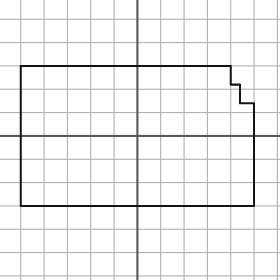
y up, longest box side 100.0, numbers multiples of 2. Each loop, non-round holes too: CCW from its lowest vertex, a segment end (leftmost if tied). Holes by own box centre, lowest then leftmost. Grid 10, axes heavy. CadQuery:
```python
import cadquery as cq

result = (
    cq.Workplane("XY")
    .moveTo(-50.0, -30.0)
    .lineTo(50.0, -30.0)
    .lineTo(50.0, 14.0)
    .lineTo(44.0, 14.0)
    .lineTo(44.0, 22.0)
    .lineTo(40.0, 22.0)
    .lineTo(40.0, 30.0)
    .lineTo(-50.0, 30.0)
    .close()
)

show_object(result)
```